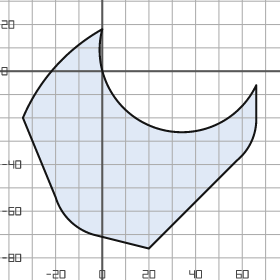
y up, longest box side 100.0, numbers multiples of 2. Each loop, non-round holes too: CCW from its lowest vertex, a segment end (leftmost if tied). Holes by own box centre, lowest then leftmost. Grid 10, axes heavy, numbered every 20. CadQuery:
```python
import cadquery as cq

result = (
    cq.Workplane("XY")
    .moveTo(20.0, -76.0)
    .lineTo(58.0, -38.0)
    .threePointArc((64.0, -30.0), (66.0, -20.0))
    .lineTo(66.0, -6.0)
    .threePointArc((22.0, -24.0), (0.0, 18.0))
    .threePointArc((-20.0, 2.0), (-34.0, -20.0))
    .lineTo(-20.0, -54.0)
    .threePointArc((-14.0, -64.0), (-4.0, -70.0))
    .close()
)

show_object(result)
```